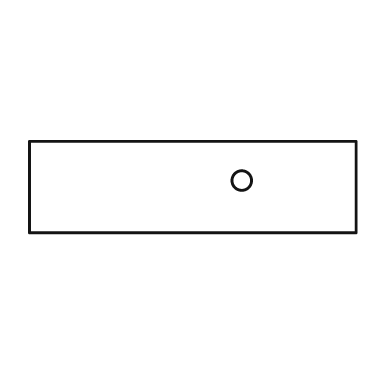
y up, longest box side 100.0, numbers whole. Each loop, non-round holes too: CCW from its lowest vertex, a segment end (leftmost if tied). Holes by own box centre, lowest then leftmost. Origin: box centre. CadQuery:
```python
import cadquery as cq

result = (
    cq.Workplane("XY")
    .moveTo(-50.0, -14.0)
    .lineTo(50.0, -14.0)
    .lineTo(50.0, 14.0)
    .lineTo(-50.0, 14.0)
    .close()
    .moveTo(15.0, 2.0)
    .circle(3.0)
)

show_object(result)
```